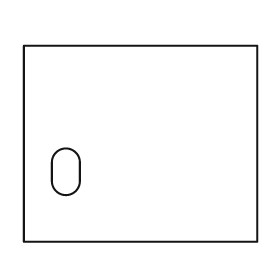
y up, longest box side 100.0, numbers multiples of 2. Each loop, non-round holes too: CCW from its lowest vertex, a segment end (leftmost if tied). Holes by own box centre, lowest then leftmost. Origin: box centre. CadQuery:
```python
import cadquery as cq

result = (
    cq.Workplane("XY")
    .moveTo(-50.0, -42.0)
    .lineTo(50.0, -42.0)
    .lineTo(50.0, 42.0)
    .lineTo(-50.0, 42.0)
    .close()
    .moveTo(-38.0, -16.0)
    .threePointArc((-32.0, -22.0), (-26.0, -16.0))
    .lineTo(-26.0, -8.0)
    .threePointArc((-32.0, -2.0), (-38.0, -8.0))
    .close()
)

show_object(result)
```